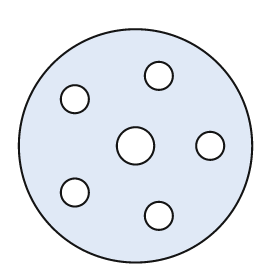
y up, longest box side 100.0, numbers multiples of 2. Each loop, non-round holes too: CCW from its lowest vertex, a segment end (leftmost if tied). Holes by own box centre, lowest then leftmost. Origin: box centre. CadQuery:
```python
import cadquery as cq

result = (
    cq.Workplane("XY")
    .moveTo(0.0, 0.0)
    .circle(50.0)
    .moveTo(10.0, -30.0)
    .circle(6.0)
    .moveTo(-26.0, -20.0)
    .circle(6.0)
    .moveTo(0.0, 0.0)
    .circle(8.0)
    .moveTo(32.0, 0.0)
    .circle(6.0)
    .moveTo(-26.0, 20.0)
    .circle(6.0)
    .moveTo(10.0, 30.0)
    .circle(6.0)
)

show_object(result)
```